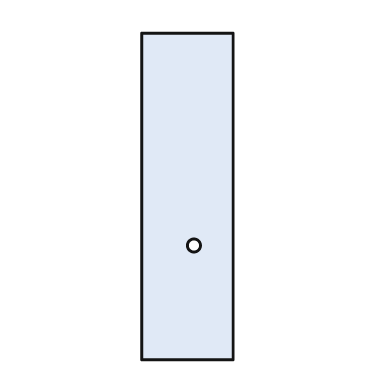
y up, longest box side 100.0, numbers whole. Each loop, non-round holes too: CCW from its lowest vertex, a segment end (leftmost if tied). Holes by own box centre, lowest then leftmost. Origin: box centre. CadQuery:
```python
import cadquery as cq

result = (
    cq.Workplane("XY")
    .moveTo(-14.0, -50.0)
    .lineTo(14.0, -50.0)
    .lineTo(14.0, 50.0)
    .lineTo(-14.0, 50.0)
    .close()
    .moveTo(2.0, -15.0)
    .circle(2.0)
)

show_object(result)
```